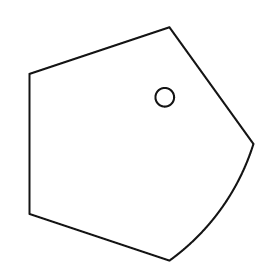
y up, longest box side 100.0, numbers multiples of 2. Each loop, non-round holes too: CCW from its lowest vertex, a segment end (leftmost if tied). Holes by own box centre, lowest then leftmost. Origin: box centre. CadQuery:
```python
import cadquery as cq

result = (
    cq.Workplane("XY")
    .moveTo(12.0, -50.0)
    .threePointArc((34.0, -28.0), (48.0, 0.0))
    .lineTo(12.0, 50.0)
    .lineTo(-48.0, 30.0)
    .lineTo(-48.0, -30.0)
    .close()
    .moveTo(10.0, 20.0)
    .circle(4.0)
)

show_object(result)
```